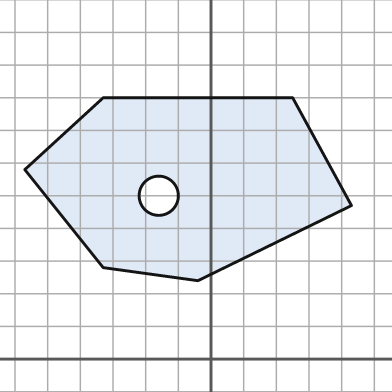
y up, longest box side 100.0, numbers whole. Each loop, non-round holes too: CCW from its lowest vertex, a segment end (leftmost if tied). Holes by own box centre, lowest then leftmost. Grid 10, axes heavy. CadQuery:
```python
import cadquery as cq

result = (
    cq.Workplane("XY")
    .moveTo(-4.0, 24.0)
    .lineTo(43.0, 47.0)
    .lineTo(25.0, 80.0)
    .lineTo(-33.0, 80.0)
    .lineTo(-57.0, 58.0)
    .lineTo(-33.0, 28.0)
    .close()
    .moveTo(-16.0, 50.0)
    .circle(6.0)
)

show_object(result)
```